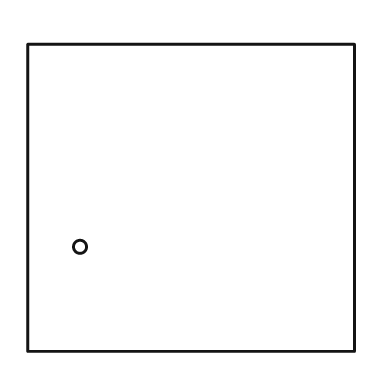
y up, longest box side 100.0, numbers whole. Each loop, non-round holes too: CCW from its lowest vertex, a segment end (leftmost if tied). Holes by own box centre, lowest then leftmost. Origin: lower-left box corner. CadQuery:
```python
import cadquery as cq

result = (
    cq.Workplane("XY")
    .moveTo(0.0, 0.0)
    .lineTo(100.0, 0.0)
    .lineTo(100.0, 94.0)
    .lineTo(0.0, 94.0)
    .close()
    .moveTo(16.0, 32.0)
    .circle(2.0)
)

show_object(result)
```